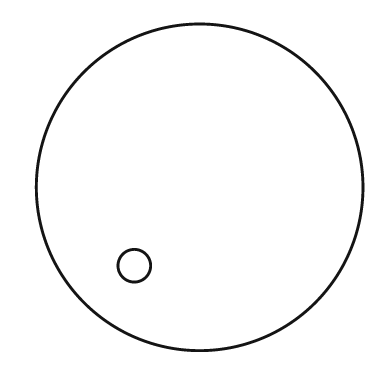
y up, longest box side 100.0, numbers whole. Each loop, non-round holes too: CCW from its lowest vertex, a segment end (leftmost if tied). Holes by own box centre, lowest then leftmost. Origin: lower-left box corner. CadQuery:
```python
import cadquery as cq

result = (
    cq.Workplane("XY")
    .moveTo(50.0, 50.0)
    .circle(50.0)
    .moveTo(30.0, 26.0)
    .circle(5.0)
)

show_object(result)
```